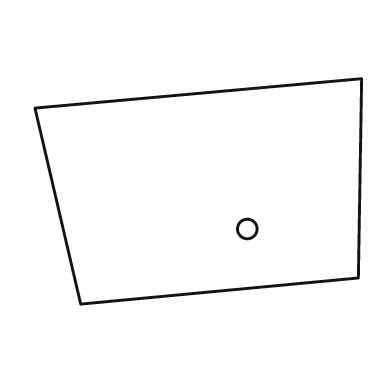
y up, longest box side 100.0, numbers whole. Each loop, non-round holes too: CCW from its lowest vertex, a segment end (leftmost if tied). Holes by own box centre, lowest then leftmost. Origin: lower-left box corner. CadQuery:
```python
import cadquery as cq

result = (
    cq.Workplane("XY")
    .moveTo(14.0, 0.0)
    .lineTo(99.0, 8.0)
    .lineTo(100.0, 69.0)
    .lineTo(0.0, 60.0)
    .close()
    .moveTo(65.0, 23.0)
    .circle(3.0)
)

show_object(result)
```